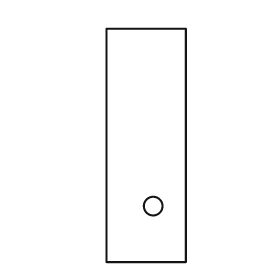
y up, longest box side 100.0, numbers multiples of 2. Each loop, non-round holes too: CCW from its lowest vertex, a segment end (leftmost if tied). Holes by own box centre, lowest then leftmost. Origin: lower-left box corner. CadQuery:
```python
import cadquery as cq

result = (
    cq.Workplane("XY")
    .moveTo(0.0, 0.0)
    .lineTo(34.0, 0.0)
    .lineTo(34.0, 100.0)
    .lineTo(0.0, 100.0)
    .close()
    .moveTo(20.0, 24.0)
    .circle(4.0)
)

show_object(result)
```